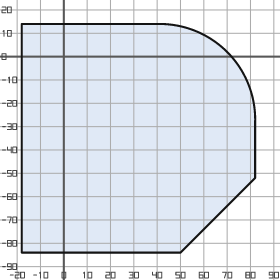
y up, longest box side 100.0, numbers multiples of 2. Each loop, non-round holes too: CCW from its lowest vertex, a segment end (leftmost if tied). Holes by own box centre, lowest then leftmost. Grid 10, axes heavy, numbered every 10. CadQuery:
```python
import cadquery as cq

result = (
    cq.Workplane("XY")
    .moveTo(-18.0, -84.0)
    .lineTo(50.0, -84.0)
    .lineTo(82.0, -52.0)
    .lineTo(82.0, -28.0)
    .threePointArc((70.0, 2.0), (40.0, 14.0))
    .lineTo(-18.0, 14.0)
    .close()
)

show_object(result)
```